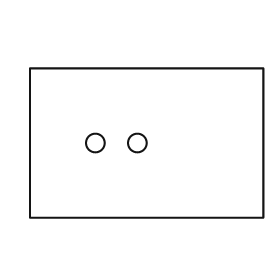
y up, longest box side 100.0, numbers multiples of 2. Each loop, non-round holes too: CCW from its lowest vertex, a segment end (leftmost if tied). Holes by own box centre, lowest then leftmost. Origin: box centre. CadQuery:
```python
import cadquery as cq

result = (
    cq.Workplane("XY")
    .moveTo(-50.0, -32.0)
    .lineTo(50.0, -32.0)
    .lineTo(50.0, 32.0)
    .lineTo(-50.0, 32.0)
    .close()
    .moveTo(-22.0, 0.0)
    .circle(4.0)
    .moveTo(-4.0, 0.0)
    .circle(4.0)
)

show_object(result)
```